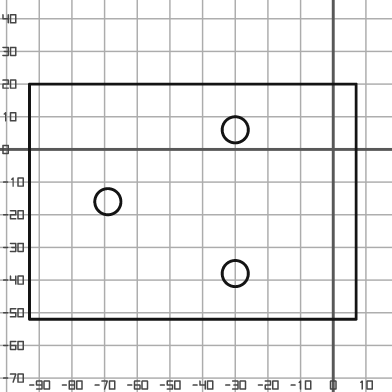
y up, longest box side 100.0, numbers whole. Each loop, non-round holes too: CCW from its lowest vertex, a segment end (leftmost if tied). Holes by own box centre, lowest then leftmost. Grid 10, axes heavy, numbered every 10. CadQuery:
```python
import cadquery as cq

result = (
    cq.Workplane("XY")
    .moveTo(-93.0, -52.0)
    .lineTo(7.0, -52.0)
    .lineTo(7.0, 20.0)
    .lineTo(-93.0, 20.0)
    .close()
    .moveTo(-30.0, -38.0)
    .circle(4.0)
    .moveTo(-69.0, -16.0)
    .circle(4.0)
    .moveTo(-30.0, 6.0)
    .circle(4.0)
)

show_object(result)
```